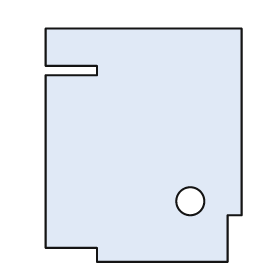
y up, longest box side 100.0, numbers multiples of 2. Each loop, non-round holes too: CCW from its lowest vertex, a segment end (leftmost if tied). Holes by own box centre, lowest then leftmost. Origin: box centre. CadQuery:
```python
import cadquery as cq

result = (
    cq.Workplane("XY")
    .moveTo(-20.0, -50.0)
    .lineTo(36.0, -50.0)
    .lineTo(36.0, -30.0)
    .lineTo(42.0, -30.0)
    .lineTo(42.0, 50.0)
    .lineTo(-42.0, 50.0)
    .lineTo(-42.0, 34.0)
    .lineTo(-20.0, 34.0)
    .lineTo(-20.0, 30.0)
    .lineTo(-42.0, 30.0)
    .lineTo(-42.0, -44.0)
    .lineTo(-20.0, -44.0)
    .close()
    .moveTo(20.0, -24.0)
    .circle(6.0)
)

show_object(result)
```